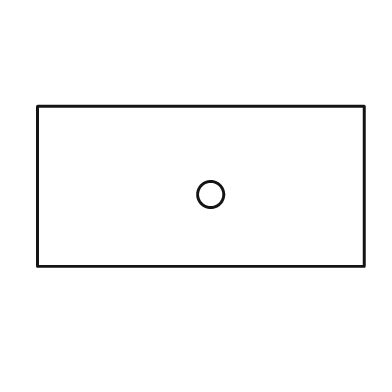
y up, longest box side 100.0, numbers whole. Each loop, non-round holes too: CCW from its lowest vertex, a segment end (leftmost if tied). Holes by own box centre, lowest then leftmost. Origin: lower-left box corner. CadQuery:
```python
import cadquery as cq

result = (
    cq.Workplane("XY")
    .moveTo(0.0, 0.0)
    .lineTo(100.0, 0.0)
    .lineTo(100.0, 49.0)
    .lineTo(0.0, 49.0)
    .close()
    .moveTo(53.0, 22.0)
    .circle(4.0)
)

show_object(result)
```